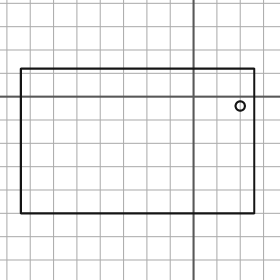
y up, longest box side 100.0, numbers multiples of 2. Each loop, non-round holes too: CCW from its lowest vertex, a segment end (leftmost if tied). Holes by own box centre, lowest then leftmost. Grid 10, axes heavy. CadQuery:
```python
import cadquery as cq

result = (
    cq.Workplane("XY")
    .moveTo(-74.0, -50.0)
    .lineTo(26.0, -50.0)
    .lineTo(26.0, 12.0)
    .lineTo(-74.0, 12.0)
    .close()
    .moveTo(20.0, -4.0)
    .circle(2.0)
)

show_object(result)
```